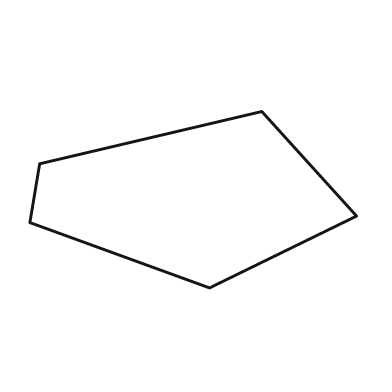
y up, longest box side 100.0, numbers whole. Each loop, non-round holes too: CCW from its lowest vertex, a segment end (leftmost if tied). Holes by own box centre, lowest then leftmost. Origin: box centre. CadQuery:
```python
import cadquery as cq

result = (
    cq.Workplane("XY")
    .moveTo(5.0, -27.0)
    .lineTo(50.0, -5.0)
    .lineTo(21.0, 27.0)
    .lineTo(-47.0, 11.0)
    .lineTo(-50.0, -7.0)
    .close()
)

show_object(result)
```